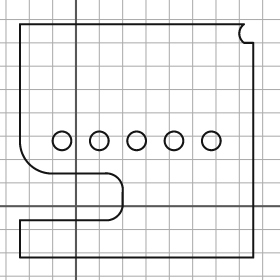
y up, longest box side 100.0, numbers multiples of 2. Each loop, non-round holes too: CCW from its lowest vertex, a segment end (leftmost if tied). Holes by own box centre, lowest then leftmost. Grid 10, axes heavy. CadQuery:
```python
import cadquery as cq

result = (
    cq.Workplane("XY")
    .moveTo(-24.0, -22.0)
    .lineTo(76.0, -22.0)
    .lineTo(76.0, 70.0)
    .lineTo(72.0, 70.0)
    .threePointArc((70.0, 74.0), (72.0, 78.0))
    .lineTo(-24.0, 78.0)
    .lineTo(-24.0, 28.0)
    .threePointArc((-20.0, 18.0), (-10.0, 14.0))
    .lineTo(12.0, 14.0)
    .threePointArc((18.0, 12.0), (20.0, 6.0))
    .lineTo(20.0, 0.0)
    .threePointArc((18.0, -4.0), (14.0, -6.0))
    .lineTo(-24.0, -6.0)
    .close()
    .moveTo(-6.0, 28.0)
    .circle(4.0)
    .moveTo(10.0, 28.0)
    .circle(4.0)
    .moveTo(26.0, 28.0)
    .circle(4.0)
    .moveTo(42.0, 28.0)
    .circle(4.0)
    .moveTo(58.0, 28.0)
    .circle(4.0)
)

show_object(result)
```